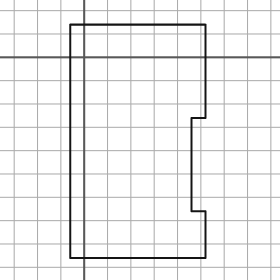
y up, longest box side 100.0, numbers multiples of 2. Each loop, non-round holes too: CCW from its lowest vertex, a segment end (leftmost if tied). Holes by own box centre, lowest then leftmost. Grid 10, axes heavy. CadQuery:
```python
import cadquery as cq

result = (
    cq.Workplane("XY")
    .moveTo(-6.0, -86.0)
    .lineTo(52.0, -86.0)
    .lineTo(52.0, -66.0)
    .lineTo(46.0, -66.0)
    .lineTo(46.0, -26.0)
    .lineTo(52.0, -26.0)
    .lineTo(52.0, 14.0)
    .lineTo(-6.0, 14.0)
    .close()
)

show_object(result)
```